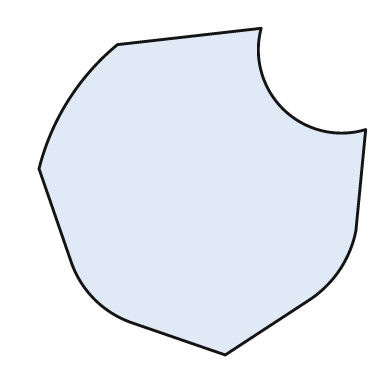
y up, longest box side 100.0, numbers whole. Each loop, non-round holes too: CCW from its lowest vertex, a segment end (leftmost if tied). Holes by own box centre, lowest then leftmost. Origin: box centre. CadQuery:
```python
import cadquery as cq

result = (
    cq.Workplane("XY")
    .moveTo(7.0, -50.0)
    .lineTo(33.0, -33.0)
    .threePointArc((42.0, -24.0), (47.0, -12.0))
    .lineTo(50.0, 19.0)
    .threePointArc((25.0, 25.0), (18.0, 50.0))
    .lineTo(-26.0, 45.0)
    .threePointArc((-41.0, 28.0), (-50.0, 7.0))
    .lineTo(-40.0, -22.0)
    .threePointArc((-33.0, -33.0), (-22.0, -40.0))
    .close()
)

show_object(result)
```